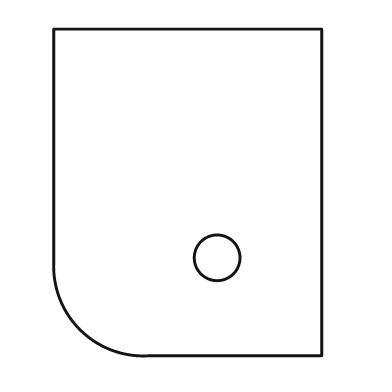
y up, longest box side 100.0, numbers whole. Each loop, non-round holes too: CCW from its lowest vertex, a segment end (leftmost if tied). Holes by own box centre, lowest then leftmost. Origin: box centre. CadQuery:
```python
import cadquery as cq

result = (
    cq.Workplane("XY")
    .moveTo(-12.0, -50.0)
    .lineTo(41.0, -50.0)
    .lineTo(41.0, 50.0)
    .lineTo(-41.0, 50.0)
    .lineTo(-41.0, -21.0)
    .threePointArc((-33.0, -42.0), (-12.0, -50.0))
    .close()
    .moveTo(9.0, -20.0)
    .circle(7.0)
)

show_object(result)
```